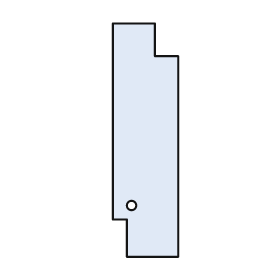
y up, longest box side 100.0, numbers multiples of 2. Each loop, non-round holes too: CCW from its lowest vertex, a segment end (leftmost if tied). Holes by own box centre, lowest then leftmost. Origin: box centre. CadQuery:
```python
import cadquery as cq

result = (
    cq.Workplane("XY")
    .moveTo(-8.0, -50.0)
    .lineTo(14.0, -50.0)
    .lineTo(14.0, 36.0)
    .lineTo(4.0, 36.0)
    .lineTo(4.0, 50.0)
    .lineTo(-14.0, 50.0)
    .lineTo(-14.0, -34.0)
    .lineTo(-8.0, -34.0)
    .close()
    .moveTo(-6.0, -28.0)
    .circle(2.0)
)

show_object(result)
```